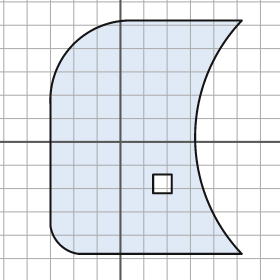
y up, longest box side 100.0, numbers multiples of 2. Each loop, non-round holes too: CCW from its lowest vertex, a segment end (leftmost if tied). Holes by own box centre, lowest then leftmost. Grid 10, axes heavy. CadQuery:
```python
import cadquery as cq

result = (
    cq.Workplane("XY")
    .moveTo(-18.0, -48.0)
    .lineTo(52.0, -48.0)
    .threePointArc((32.0, 2.0), (52.0, 52.0))
    .lineTo(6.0, 52.0)
    .threePointArc((-20.0, 42.0), (-30.0, 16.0))
    .lineTo(-30.0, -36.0)
    .threePointArc((-26.0, -44.0), (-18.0, -48.0))
    .close()
    .moveTo(14.0, -22.0)
    .lineTo(22.0, -22.0)
    .lineTo(22.0, -14.0)
    .lineTo(14.0, -14.0)
    .close()
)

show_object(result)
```